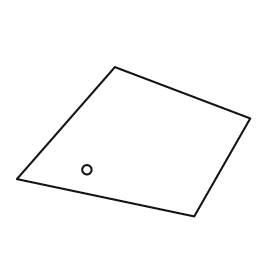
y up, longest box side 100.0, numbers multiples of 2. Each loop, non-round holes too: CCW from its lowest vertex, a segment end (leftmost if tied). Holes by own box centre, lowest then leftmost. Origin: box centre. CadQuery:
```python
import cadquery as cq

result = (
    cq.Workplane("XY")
    .moveTo(26.0, -32.0)
    .lineTo(50.0, 10.0)
    .lineTo(-8.0, 32.0)
    .lineTo(-50.0, -16.0)
    .close()
    .moveTo(-20.0, -12.0)
    .circle(2.0)
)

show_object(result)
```